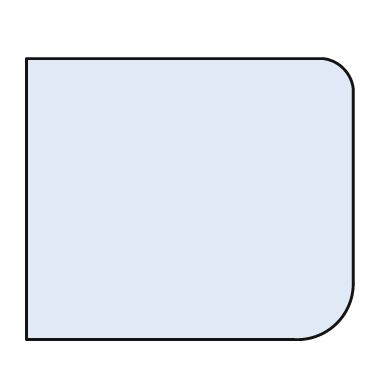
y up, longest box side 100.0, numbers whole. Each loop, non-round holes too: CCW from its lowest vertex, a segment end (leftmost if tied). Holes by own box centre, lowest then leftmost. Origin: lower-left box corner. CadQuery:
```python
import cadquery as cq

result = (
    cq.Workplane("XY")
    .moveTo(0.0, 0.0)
    .lineTo(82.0, 0.0)
    .threePointArc((95.0, 5.0), (100.0, 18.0))
    .lineTo(100.0, 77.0)
    .threePointArc((97.0, 83.0), (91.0, 86.0))
    .lineTo(0.0, 86.0)
    .close()
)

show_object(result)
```